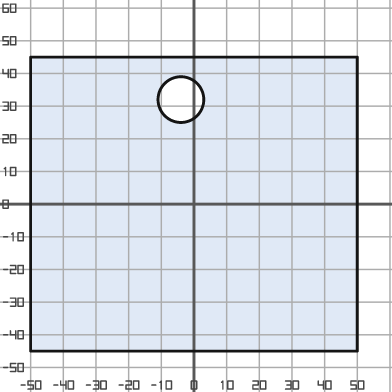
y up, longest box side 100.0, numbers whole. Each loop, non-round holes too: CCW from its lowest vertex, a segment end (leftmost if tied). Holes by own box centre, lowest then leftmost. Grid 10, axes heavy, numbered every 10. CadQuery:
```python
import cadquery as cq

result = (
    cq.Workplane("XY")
    .moveTo(-50.0, -45.0)
    .lineTo(50.0, -45.0)
    .lineTo(50.0, 45.0)
    .lineTo(-50.0, 45.0)
    .close()
    .moveTo(-4.0, 32.0)
    .circle(7.0)
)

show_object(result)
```